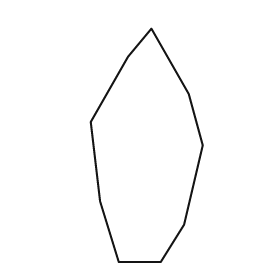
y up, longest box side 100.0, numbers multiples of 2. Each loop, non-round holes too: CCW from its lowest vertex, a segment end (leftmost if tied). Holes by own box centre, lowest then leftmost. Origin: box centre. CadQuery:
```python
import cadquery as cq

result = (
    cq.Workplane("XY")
    .moveTo(-12.0, -50.0)
    .lineTo(6.0, -50.0)
    .lineTo(16.0, -34.0)
    .lineTo(24.0, 0.0)
    .lineTo(18.0, 22.0)
    .lineTo(2.0, 50.0)
    .lineTo(-8.0, 38.0)
    .lineTo(-24.0, 10.0)
    .lineTo(-20.0, -24.0)
    .close()
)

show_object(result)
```